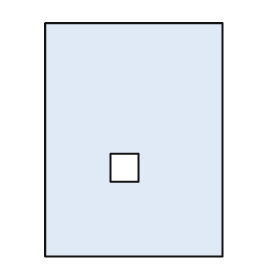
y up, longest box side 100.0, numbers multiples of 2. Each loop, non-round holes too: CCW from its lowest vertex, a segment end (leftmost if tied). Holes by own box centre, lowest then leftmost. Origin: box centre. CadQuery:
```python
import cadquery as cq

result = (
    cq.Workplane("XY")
    .moveTo(-38.0, -50.0)
    .lineTo(38.0, -50.0)
    .lineTo(38.0, 50.0)
    .lineTo(-38.0, 50.0)
    .close()
    .moveTo(-10.0, -18.0)
    .lineTo(2.0, -18.0)
    .lineTo(2.0, -6.0)
    .lineTo(-10.0, -6.0)
    .close()
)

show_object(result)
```